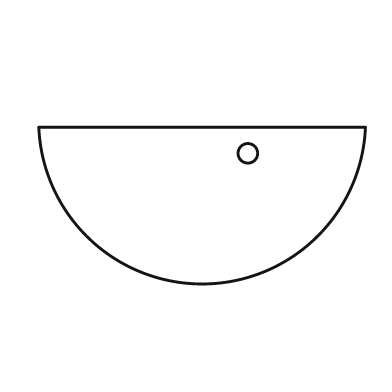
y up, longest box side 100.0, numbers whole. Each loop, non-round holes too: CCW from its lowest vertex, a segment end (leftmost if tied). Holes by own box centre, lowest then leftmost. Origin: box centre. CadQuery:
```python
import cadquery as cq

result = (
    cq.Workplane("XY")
    .moveTo(-50.0, 24.0)
    .threePointArc((0.0, -24.0), (50.0, 24.0))
    .close()
    .moveTo(14.0, 16.0)
    .circle(3.0)
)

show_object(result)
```